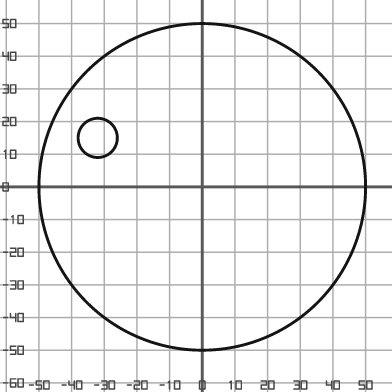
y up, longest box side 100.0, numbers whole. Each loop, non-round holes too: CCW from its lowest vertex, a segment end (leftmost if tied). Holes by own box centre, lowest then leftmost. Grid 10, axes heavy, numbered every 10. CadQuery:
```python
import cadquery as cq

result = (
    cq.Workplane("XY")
    .moveTo(0.0, 0.0)
    .circle(50.0)
    .moveTo(-32.0, 15.0)
    .circle(6.0)
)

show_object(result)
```